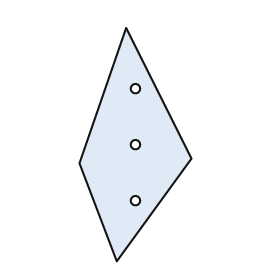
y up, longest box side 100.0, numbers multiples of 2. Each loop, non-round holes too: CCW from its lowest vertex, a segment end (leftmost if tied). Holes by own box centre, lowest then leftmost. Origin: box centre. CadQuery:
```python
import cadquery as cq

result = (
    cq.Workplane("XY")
    .moveTo(-8.0, -50.0)
    .lineTo(24.0, -6.0)
    .lineTo(-4.0, 50.0)
    .lineTo(-24.0, -8.0)
    .close()
    .moveTo(0.0, -24.0)
    .circle(2.0)
    .moveTo(0.0, 0.0)
    .circle(2.0)
    .moveTo(0.0, 24.0)
    .circle(2.0)
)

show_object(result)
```